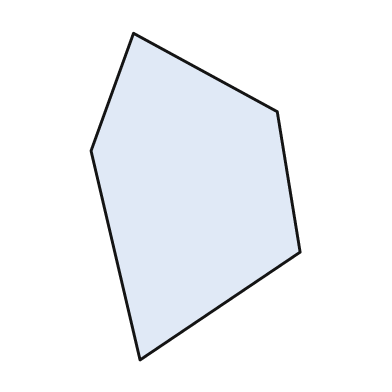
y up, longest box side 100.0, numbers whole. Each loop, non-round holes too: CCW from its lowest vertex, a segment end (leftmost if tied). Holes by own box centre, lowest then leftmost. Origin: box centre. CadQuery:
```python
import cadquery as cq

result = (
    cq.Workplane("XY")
    .moveTo(-17.0, -50.0)
    .lineTo(32.0, -17.0)
    .lineTo(25.0, 26.0)
    .lineTo(-19.0, 50.0)
    .lineTo(-32.0, 14.0)
    .close()
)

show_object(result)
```